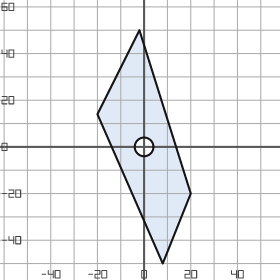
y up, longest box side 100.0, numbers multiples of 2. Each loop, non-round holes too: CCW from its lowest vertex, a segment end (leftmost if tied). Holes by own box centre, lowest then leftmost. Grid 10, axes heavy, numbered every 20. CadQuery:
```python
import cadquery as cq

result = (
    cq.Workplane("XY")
    .moveTo(8.0, -50.0)
    .lineTo(20.0, -20.0)
    .lineTo(-2.0, 50.0)
    .lineTo(-20.0, 14.0)
    .close()
    .moveTo(0.0, 0.0)
    .circle(4.0)
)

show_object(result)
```